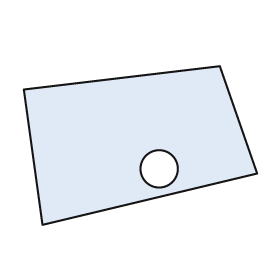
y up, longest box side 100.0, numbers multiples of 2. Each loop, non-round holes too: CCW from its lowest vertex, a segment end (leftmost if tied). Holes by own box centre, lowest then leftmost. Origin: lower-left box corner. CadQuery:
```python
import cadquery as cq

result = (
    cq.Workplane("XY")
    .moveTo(8.0, 0.0)
    .lineTo(100.0, 22.0)
    .lineTo(84.0, 68.0)
    .lineTo(0.0, 58.0)
    .close()
    .moveTo(58.0, 24.0)
    .circle(8.0)
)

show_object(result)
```